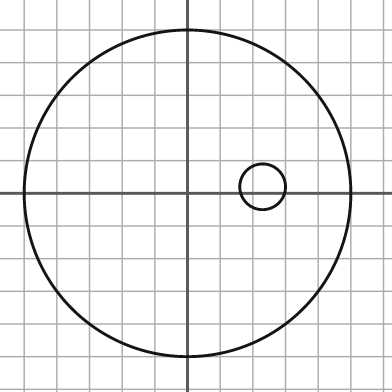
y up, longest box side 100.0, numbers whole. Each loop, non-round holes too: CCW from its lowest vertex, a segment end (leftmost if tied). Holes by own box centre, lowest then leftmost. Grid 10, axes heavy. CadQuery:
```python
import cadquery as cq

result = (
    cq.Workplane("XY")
    .moveTo(0.0, 0.0)
    .circle(50.0)
    .moveTo(23.0, 2.0)
    .circle(7.0)
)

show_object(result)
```